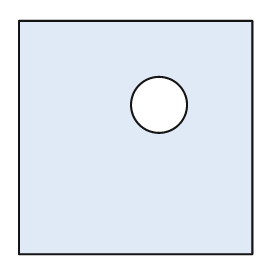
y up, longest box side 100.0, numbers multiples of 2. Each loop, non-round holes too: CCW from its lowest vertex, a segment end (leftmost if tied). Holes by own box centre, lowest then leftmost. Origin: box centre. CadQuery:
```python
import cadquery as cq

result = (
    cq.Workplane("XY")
    .moveTo(-50.0, -50.0)
    .lineTo(50.0, -50.0)
    .lineTo(50.0, 50.0)
    .lineTo(-50.0, 50.0)
    .close()
    .moveTo(10.0, 14.0)
    .circle(12.0)
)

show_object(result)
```